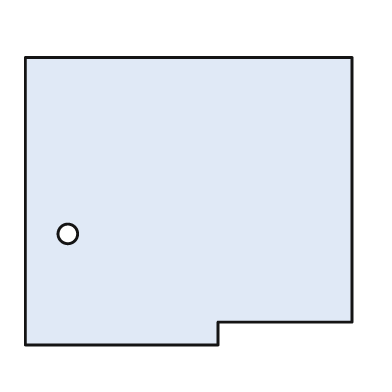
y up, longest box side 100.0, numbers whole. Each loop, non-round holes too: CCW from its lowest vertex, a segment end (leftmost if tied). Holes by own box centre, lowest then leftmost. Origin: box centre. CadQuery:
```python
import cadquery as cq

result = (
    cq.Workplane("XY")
    .moveTo(-50.0, -44.0)
    .lineTo(9.0, -44.0)
    .lineTo(9.0, -37.0)
    .lineTo(50.0, -37.0)
    .lineTo(50.0, 44.0)
    .lineTo(-50.0, 44.0)
    .close()
    .moveTo(-37.0, -10.0)
    .circle(3.0)
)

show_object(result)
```